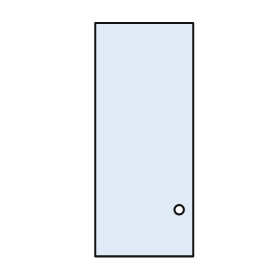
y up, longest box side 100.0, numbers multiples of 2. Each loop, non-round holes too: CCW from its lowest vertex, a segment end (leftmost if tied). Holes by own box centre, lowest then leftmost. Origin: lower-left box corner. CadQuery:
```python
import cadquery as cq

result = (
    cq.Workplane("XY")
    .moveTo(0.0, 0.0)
    .lineTo(42.0, 0.0)
    .lineTo(42.0, 100.0)
    .lineTo(0.0, 100.0)
    .close()
    .moveTo(36.0, 20.0)
    .circle(2.0)
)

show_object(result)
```